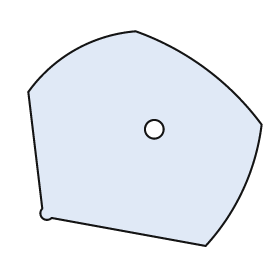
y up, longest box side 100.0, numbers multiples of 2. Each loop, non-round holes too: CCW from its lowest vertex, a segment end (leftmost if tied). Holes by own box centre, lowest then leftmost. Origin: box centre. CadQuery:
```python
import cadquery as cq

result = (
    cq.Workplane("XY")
    .moveTo(26.0, -46.0)
    .threePointArc((42.0, -22.0), (50.0, 6.0))
    .threePointArc((26.0, 30.0), (-4.0, 46.0))
    .threePointArc((-30.0, 38.0), (-50.0, 20.0))
    .lineTo(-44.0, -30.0)
    .threePointArc((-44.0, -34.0), (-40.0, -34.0))
    .close()
    .moveTo(4.0, 4.0)
    .circle(4.0)
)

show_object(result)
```